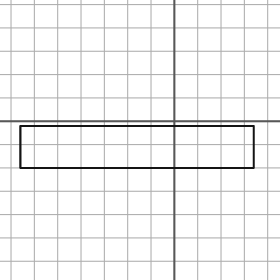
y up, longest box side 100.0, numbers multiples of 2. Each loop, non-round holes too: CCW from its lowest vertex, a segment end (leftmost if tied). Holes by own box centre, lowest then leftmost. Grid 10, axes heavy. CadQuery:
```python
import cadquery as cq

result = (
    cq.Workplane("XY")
    .moveTo(-66.0, -20.0)
    .lineTo(34.0, -20.0)
    .lineTo(34.0, -2.0)
    .lineTo(-66.0, -2.0)
    .close()
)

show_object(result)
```